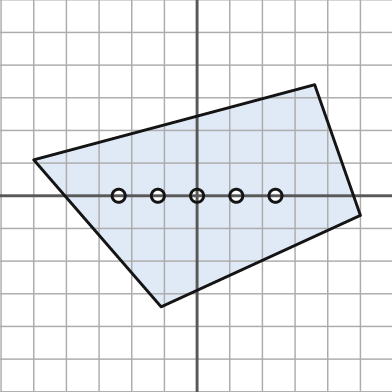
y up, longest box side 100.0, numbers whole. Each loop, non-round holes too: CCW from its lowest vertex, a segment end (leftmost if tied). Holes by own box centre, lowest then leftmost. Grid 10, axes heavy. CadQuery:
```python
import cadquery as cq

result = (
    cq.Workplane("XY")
    .moveTo(-11.0, -34.0)
    .lineTo(50.0, -6.0)
    .lineTo(36.0, 34.0)
    .lineTo(-50.0, 11.0)
    .close()
    .moveTo(-24.0, 0.0)
    .circle(2.0)
    .moveTo(-12.0, 0.0)
    .circle(2.0)
    .moveTo(0.0, 0.0)
    .circle(2.0)
    .moveTo(12.0, 0.0)
    .circle(2.0)
    .moveTo(24.0, 0.0)
    .circle(2.0)
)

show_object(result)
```